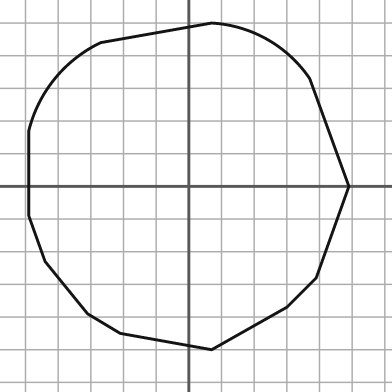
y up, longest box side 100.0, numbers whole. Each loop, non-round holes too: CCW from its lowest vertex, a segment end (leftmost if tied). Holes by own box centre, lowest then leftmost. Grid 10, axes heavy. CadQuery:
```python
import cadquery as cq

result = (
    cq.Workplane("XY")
    .moveTo(7.0, -50.0)
    .lineTo(30.0, -37.0)
    .lineTo(39.0, -28.0)
    .lineTo(49.0, 0.0)
    .lineTo(37.0, 33.0)
    .threePointArc((24.0, 45.0), (7.0, 50.0))
    .lineTo(-27.0, 44.0)
    .threePointArc((-41.0, 33.0), (-49.0, 17.0))
    .lineTo(-49.0, -9.0)
    .lineTo(-44.0, -23.0)
    .lineTo(-31.0, -39.0)
    .lineTo(-21.0, -45.0)
    .close()
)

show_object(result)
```